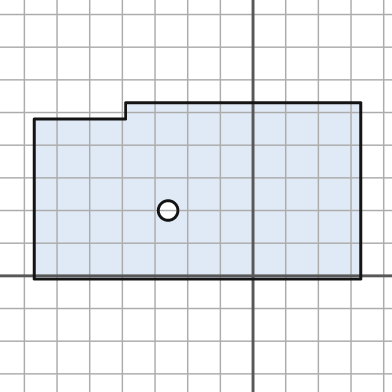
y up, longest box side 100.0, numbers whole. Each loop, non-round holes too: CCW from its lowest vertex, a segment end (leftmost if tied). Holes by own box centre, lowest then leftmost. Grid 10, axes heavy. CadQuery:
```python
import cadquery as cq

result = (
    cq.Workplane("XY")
    .moveTo(-67.0, -1.0)
    .lineTo(33.0, -1.0)
    .lineTo(33.0, 53.0)
    .lineTo(-39.0, 53.0)
    .lineTo(-39.0, 48.0)
    .lineTo(-67.0, 48.0)
    .close()
    .moveTo(-26.0, 20.0)
    .circle(3.0)
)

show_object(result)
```